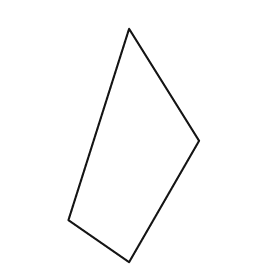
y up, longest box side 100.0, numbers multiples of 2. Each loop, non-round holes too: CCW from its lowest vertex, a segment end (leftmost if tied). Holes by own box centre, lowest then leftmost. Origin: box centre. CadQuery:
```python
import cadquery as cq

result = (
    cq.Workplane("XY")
    .moveTo(-2.0, -50.0)
    .lineTo(28.0, 2.0)
    .lineTo(-2.0, 50.0)
    .lineTo(-28.0, -32.0)
    .close()
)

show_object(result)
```